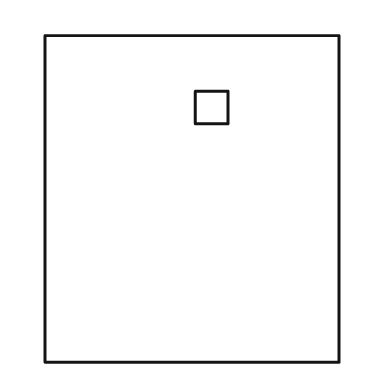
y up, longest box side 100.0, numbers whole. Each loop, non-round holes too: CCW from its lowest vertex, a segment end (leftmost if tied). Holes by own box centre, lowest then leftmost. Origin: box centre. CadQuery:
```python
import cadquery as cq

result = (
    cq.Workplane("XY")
    .moveTo(-45.0, -50.0)
    .lineTo(45.0, -50.0)
    .lineTo(45.0, 50.0)
    .lineTo(-45.0, 50.0)
    .close()
    .moveTo(1.0, 23.0)
    .lineTo(11.0, 23.0)
    .lineTo(11.0, 33.0)
    .lineTo(1.0, 33.0)
    .close()
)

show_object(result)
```